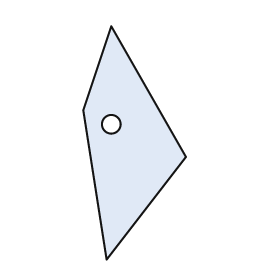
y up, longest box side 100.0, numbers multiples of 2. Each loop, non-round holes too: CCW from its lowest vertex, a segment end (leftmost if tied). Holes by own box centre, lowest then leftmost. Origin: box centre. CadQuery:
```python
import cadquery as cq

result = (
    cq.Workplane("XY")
    .moveTo(-12.0, -50.0)
    .lineTo(22.0, -6.0)
    .lineTo(-10.0, 50.0)
    .lineTo(-22.0, 14.0)
    .close()
    .moveTo(-10.0, 8.0)
    .circle(4.0)
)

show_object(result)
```